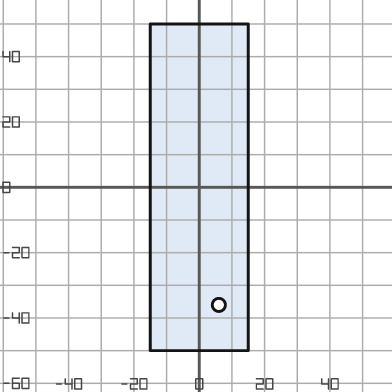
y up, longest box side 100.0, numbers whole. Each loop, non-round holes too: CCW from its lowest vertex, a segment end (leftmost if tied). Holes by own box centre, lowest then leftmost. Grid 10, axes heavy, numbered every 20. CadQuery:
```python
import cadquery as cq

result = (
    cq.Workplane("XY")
    .moveTo(-15.0, -50.0)
    .lineTo(15.0, -50.0)
    .lineTo(15.0, 50.0)
    .lineTo(-15.0, 50.0)
    .close()
    .moveTo(6.0, -36.0)
    .circle(2.0)
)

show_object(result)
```